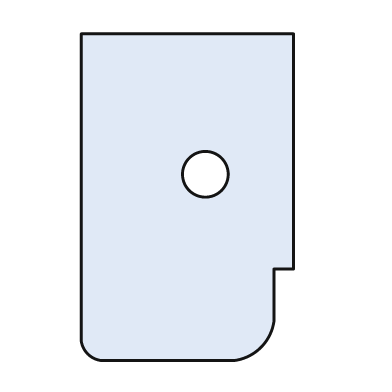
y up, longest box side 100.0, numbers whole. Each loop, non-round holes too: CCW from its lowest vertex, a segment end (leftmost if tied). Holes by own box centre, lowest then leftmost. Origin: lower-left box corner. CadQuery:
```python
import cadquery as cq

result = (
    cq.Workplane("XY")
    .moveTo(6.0, 0.0)
    .lineTo(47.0, 0.0)
    .threePointArc((55.0, 4.0), (59.0, 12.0))
    .lineTo(59.0, 28.0)
    .lineTo(65.0, 28.0)
    .lineTo(65.0, 100.0)
    .lineTo(0.0, 100.0)
    .lineTo(0.0, 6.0)
    .threePointArc((2.0, 2.0), (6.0, 0.0))
    .close()
    .moveTo(38.0, 57.0)
    .circle(7.0)
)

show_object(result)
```